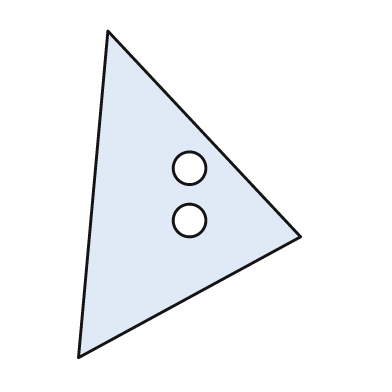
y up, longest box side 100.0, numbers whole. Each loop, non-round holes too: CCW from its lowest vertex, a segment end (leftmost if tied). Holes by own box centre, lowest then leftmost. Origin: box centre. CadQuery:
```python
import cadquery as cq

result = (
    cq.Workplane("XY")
    .moveTo(-34.0, -50.0)
    .lineTo(34.0, -13.0)
    .lineTo(-25.0, 50.0)
    .close()
    .moveTo(0.0, -8.0)
    .circle(5.0)
    .moveTo(0.0, 8.0)
    .circle(5.0)
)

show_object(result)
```